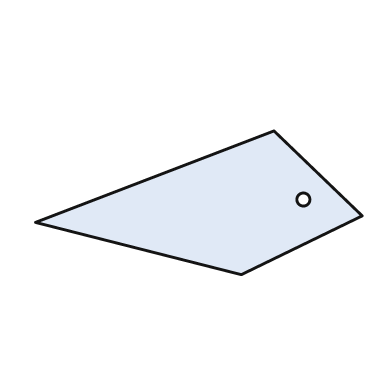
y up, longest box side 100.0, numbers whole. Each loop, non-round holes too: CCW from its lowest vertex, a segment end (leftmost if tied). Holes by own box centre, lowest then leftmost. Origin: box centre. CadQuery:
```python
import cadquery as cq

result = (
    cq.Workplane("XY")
    .moveTo(13.0, -22.0)
    .lineTo(50.0, -4.0)
    .lineTo(23.0, 22.0)
    .lineTo(-50.0, -6.0)
    .close()
    .moveTo(32.0, 1.0)
    .circle(2.0)
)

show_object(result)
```